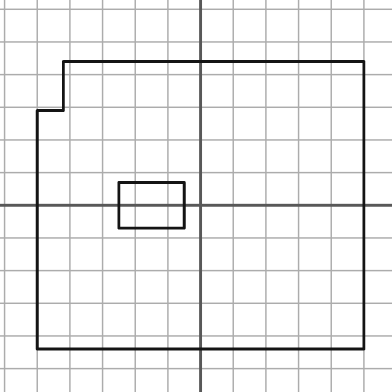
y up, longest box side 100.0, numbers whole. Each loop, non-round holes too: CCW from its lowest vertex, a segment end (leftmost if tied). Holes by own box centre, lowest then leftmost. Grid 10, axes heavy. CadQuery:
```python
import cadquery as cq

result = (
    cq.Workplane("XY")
    .moveTo(-50.0, -44.0)
    .lineTo(50.0, -44.0)
    .lineTo(50.0, 44.0)
    .lineTo(-42.0, 44.0)
    .lineTo(-42.0, 29.0)
    .lineTo(-50.0, 29.0)
    .close()
    .moveTo(-25.0, -7.0)
    .lineTo(-5.0, -7.0)
    .lineTo(-5.0, 7.0)
    .lineTo(-25.0, 7.0)
    .close()
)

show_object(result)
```